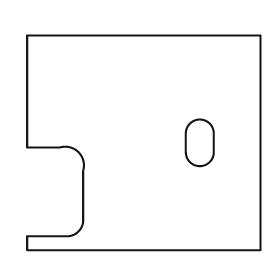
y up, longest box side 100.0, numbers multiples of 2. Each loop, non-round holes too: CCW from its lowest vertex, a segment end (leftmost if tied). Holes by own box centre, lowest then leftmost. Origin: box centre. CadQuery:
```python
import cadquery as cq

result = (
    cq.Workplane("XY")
    .moveTo(-50.0, -46.0)
    .lineTo(50.0, -46.0)
    .lineTo(50.0, 46.0)
    .lineTo(-50.0, 46.0)
    .lineTo(-50.0, -2.0)
    .lineTo(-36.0, -2.0)
    .threePointArc((-28.0, -4.0), (-26.0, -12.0))
    .lineTo(-26.0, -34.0)
    .threePointArc((-28.0, -38.0), (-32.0, -40.0))
    .lineTo(-50.0, -40.0)
    .close()
    .moveTo(18.0, -4.0)
    .threePointArc((24.0, -10.0), (30.0, -4.0))
    .lineTo(30.0, 4.0)
    .threePointArc((24.0, 10.0), (18.0, 4.0))
    .close()
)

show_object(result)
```